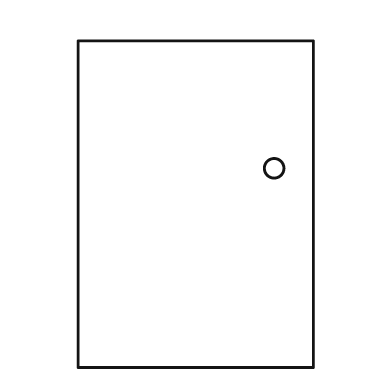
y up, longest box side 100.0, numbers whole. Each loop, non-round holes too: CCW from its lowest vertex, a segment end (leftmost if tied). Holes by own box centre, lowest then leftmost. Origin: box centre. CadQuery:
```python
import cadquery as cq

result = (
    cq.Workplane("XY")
    .moveTo(-36.0, -50.0)
    .lineTo(36.0, -50.0)
    .lineTo(36.0, 50.0)
    .lineTo(-36.0, 50.0)
    .close()
    .moveTo(24.0, 11.0)
    .circle(3.0)
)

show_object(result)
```